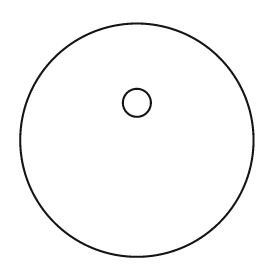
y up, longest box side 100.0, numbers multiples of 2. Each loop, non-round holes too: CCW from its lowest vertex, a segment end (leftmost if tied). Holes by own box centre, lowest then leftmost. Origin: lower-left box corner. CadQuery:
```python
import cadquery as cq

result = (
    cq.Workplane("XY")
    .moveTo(50.0, 50.0)
    .circle(50.0)
    .moveTo(50.0, 66.0)
    .circle(6.0)
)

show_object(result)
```